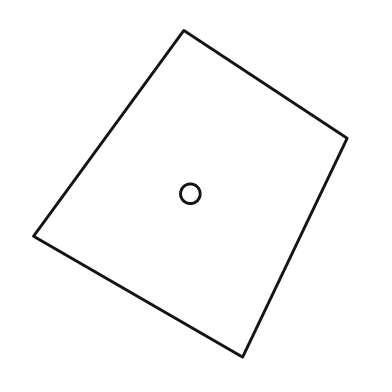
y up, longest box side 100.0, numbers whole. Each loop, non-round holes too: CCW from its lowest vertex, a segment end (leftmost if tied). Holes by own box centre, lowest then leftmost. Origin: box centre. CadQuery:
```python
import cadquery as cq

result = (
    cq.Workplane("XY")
    .moveTo(16.0, -50.0)
    .lineTo(48.0, 17.0)
    .lineTo(-2.0, 50.0)
    .lineTo(-48.0, -13.0)
    .close()
    .moveTo(0.0, 0.0)
    .circle(3.0)
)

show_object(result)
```